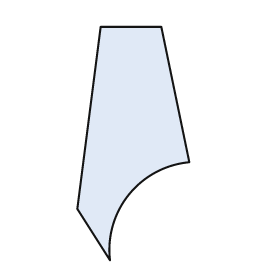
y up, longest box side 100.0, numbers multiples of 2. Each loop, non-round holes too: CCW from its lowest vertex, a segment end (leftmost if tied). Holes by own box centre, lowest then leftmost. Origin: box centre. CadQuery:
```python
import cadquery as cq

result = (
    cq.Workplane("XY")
    .moveTo(-10.0, -50.0)
    .threePointArc((-2.0, -22.0), (24.0, -8.0))
    .lineTo(12.0, 50.0)
    .lineTo(-14.0, 50.0)
    .lineTo(-24.0, -28.0)
    .close()
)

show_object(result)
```